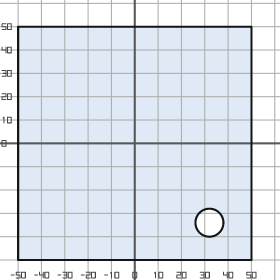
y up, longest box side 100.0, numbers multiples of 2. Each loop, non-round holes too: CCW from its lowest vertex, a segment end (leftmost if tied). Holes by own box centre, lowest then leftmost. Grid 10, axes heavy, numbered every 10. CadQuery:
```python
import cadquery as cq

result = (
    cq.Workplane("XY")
    .moveTo(-50.0, -50.0)
    .lineTo(50.0, -50.0)
    .lineTo(50.0, 50.0)
    .lineTo(-50.0, 50.0)
    .close()
    .moveTo(32.0, -34.0)
    .circle(6.0)
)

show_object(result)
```